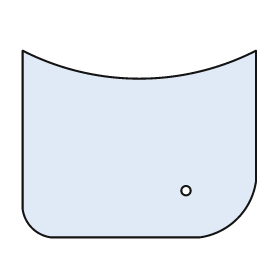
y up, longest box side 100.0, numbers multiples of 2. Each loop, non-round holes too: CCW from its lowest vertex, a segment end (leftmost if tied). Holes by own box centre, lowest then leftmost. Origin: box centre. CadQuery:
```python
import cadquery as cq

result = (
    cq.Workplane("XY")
    .moveTo(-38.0, -40.0)
    .lineTo(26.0, -40.0)
    .threePointArc((42.0, -32.0), (50.0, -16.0))
    .lineTo(50.0, 40.0)
    .threePointArc((0.0, 28.0), (-50.0, 40.0))
    .lineTo(-50.0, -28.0)
    .threePointArc((-46.0, -36.0), (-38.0, -40.0))
    .close()
    .moveTo(20.0, -20.0)
    .circle(2.0)
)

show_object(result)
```